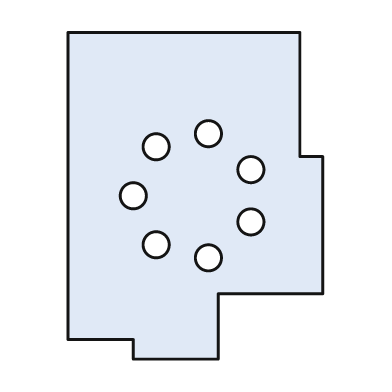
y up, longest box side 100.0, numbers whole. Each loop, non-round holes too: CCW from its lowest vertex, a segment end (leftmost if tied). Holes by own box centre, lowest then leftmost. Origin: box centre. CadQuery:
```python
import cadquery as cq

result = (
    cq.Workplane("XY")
    .moveTo(-19.0, -50.0)
    .lineTo(7.0, -50.0)
    .lineTo(7.0, -30.0)
    .lineTo(39.0, -30.0)
    .lineTo(39.0, 12.0)
    .lineTo(32.0, 12.0)
    .lineTo(32.0, 50.0)
    .lineTo(-39.0, 50.0)
    .lineTo(-39.0, -44.0)
    .lineTo(-19.0, -44.0)
    .close()
    .moveTo(4.0, -19.0)
    .circle(4.0)
    .moveTo(-12.0, -15.0)
    .circle(4.0)
    .moveTo(17.0, -8.0)
    .circle(4.0)
    .moveTo(-19.0, 0.0)
    .circle(4.0)
    .moveTo(17.0, 8.0)
    .circle(4.0)
    .moveTo(-12.0, 15.0)
    .circle(4.0)
    .moveTo(4.0, 19.0)
    .circle(4.0)
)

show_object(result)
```